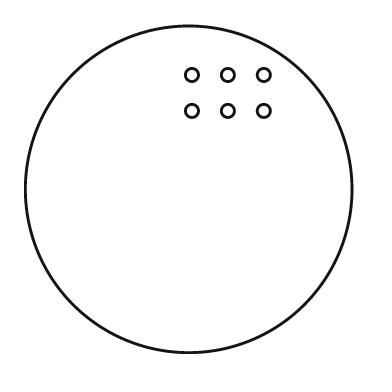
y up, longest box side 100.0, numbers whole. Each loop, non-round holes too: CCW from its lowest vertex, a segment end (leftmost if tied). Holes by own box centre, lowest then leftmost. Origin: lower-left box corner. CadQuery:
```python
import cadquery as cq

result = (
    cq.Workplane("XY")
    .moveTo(50.0, 50.0)
    .circle(50.0)
    .moveTo(51.0, 74.0)
    .circle(2.0)
    .moveTo(62.0, 74.0)
    .circle(2.0)
    .moveTo(73.0, 74.0)
    .circle(2.0)
    .moveTo(51.0, 85.0)
    .circle(2.0)
    .moveTo(62.0, 85.0)
    .circle(2.0)
    .moveTo(73.0, 85.0)
    .circle(2.0)
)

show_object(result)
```